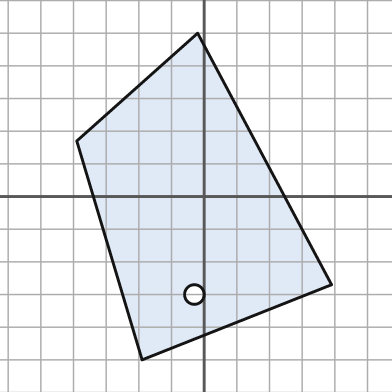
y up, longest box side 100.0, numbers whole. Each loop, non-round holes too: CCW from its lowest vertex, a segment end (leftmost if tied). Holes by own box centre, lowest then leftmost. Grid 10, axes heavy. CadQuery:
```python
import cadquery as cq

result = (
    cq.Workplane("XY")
    .moveTo(-19.0, -50.0)
    .lineTo(39.0, -27.0)
    .lineTo(-2.0, 50.0)
    .lineTo(-39.0, 17.0)
    .close()
    .moveTo(-3.0, -30.0)
    .circle(3.0)
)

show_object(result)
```